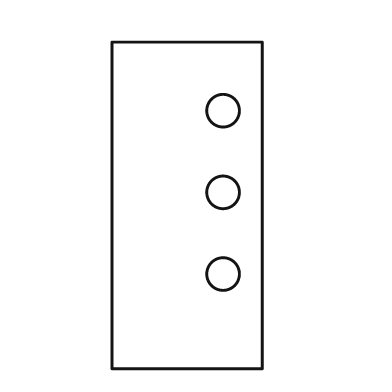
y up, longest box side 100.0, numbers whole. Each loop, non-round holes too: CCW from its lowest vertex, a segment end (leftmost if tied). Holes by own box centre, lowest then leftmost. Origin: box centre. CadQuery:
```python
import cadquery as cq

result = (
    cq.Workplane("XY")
    .moveTo(-23.0, -50.0)
    .lineTo(23.0, -50.0)
    .lineTo(23.0, 50.0)
    .lineTo(-23.0, 50.0)
    .close()
    .moveTo(11.0, -21.0)
    .circle(5.0)
    .moveTo(11.0, 4.0)
    .circle(5.0)
    .moveTo(11.0, 29.0)
    .circle(5.0)
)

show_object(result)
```